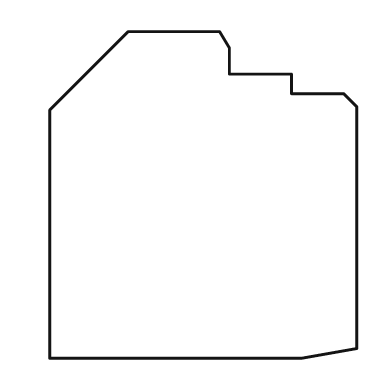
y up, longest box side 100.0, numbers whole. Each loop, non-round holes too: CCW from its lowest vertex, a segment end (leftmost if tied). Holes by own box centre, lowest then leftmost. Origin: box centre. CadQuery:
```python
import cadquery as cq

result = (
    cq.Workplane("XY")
    .moveTo(-47.0, -50.0)
    .lineTo(30.0, -50.0)
    .lineTo(47.0, -47.0)
    .lineTo(47.0, 27.0)
    .lineTo(43.0, 31.0)
    .lineTo(27.0, 31.0)
    .lineTo(27.0, 37.0)
    .lineTo(8.0, 37.0)
    .lineTo(8.0, 45.0)
    .lineTo(5.0, 50.0)
    .lineTo(-23.0, 50.0)
    .lineTo(-47.0, 26.0)
    .close()
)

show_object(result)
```